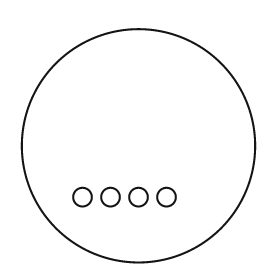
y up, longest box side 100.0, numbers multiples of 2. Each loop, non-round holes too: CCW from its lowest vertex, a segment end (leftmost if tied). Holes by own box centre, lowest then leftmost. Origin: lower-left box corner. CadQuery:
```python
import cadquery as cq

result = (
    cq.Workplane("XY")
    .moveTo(50.0, 50.0)
    .circle(50.0)
    .moveTo(26.0, 28.0)
    .circle(4.0)
    .moveTo(38.0, 28.0)
    .circle(4.0)
    .moveTo(50.0, 28.0)
    .circle(4.0)
    .moveTo(62.0, 28.0)
    .circle(4.0)
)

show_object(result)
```